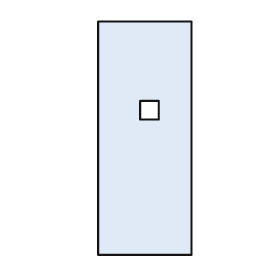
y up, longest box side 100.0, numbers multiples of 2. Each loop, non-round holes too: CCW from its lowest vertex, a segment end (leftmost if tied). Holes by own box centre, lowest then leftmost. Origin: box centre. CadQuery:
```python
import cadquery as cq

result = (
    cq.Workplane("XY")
    .moveTo(-20.0, -50.0)
    .lineTo(20.0, -50.0)
    .lineTo(20.0, 50.0)
    .lineTo(-20.0, 50.0)
    .close()
    .moveTo(-2.0, 8.0)
    .lineTo(6.0, 8.0)
    .lineTo(6.0, 16.0)
    .lineTo(-2.0, 16.0)
    .close()
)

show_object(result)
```